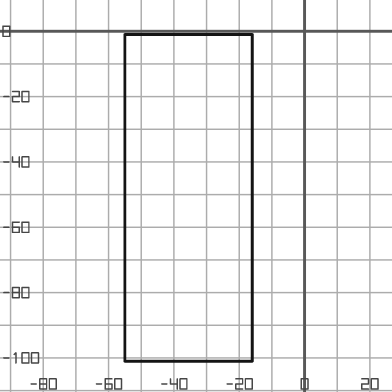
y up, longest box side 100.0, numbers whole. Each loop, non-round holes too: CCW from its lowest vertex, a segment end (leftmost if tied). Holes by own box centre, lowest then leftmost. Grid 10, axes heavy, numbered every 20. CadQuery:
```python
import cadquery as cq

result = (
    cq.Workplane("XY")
    .moveTo(-55.0, -101.0)
    .lineTo(-16.0, -101.0)
    .lineTo(-16.0, -1.0)
    .lineTo(-55.0, -1.0)
    .close()
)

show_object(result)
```